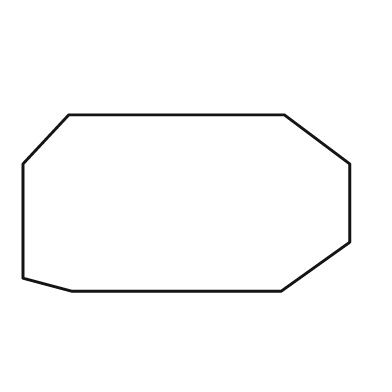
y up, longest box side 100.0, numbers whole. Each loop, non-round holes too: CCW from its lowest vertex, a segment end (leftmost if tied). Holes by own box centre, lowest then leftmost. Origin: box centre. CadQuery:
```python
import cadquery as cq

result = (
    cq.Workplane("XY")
    .moveTo(-35.0, -27.0)
    .lineTo(29.0, -27.0)
    .lineTo(50.0, -12.0)
    .lineTo(50.0, 12.0)
    .lineTo(30.0, 27.0)
    .lineTo(-36.0, 27.0)
    .lineTo(-50.0, 12.0)
    .lineTo(-50.0, -23.0)
    .close()
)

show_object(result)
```